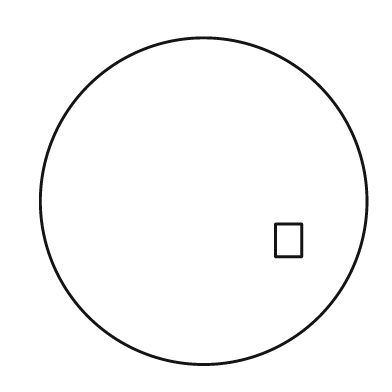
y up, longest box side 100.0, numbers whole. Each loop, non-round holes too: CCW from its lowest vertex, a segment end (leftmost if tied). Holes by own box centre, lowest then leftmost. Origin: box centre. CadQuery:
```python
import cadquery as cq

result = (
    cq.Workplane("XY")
    .moveTo(0.0, 0.0)
    .circle(50.0)
    .moveTo(22.0, -17.0)
    .lineTo(30.0, -17.0)
    .lineTo(30.0, -7.0)
    .lineTo(22.0, -7.0)
    .close()
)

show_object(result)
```